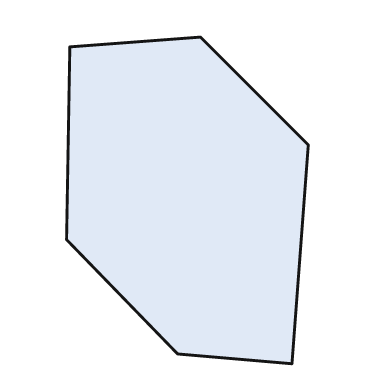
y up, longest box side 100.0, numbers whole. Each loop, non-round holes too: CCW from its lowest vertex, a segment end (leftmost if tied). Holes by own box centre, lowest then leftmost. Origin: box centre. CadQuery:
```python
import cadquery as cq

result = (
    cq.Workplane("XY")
    .moveTo(32.0, -50.0)
    .lineTo(37.0, 17.0)
    .lineTo(4.0, 50.0)
    .lineTo(-36.0, 47.0)
    .lineTo(-37.0, -12.0)
    .lineTo(-3.0, -47.0)
    .close()
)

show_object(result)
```